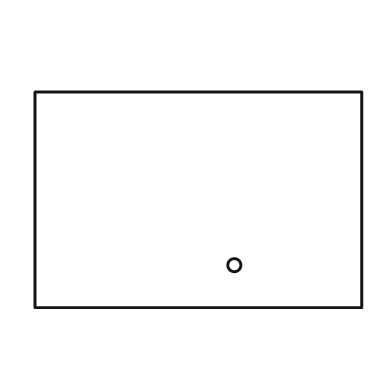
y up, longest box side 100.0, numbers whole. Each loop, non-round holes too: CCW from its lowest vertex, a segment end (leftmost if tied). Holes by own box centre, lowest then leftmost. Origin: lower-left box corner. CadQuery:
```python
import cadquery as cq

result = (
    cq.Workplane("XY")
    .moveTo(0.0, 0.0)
    .lineTo(100.0, 0.0)
    .lineTo(100.0, 66.0)
    .lineTo(0.0, 66.0)
    .close()
    .moveTo(61.0, 13.0)
    .circle(2.0)
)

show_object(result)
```